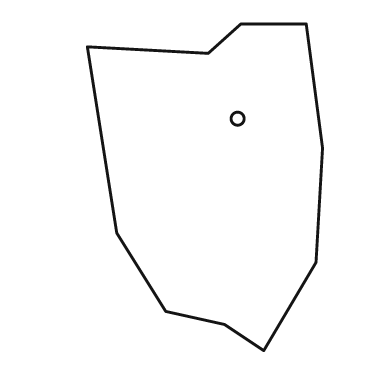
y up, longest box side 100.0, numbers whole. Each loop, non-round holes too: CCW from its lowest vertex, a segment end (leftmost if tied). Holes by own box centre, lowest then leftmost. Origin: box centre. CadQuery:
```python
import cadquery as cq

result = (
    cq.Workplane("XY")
    .moveTo(18.0, -50.0)
    .lineTo(34.0, -23.0)
    .lineTo(36.0, 12.0)
    .lineTo(31.0, 50.0)
    .lineTo(11.0, 50.0)
    .lineTo(1.0, 41.0)
    .lineTo(-36.0, 43.0)
    .lineTo(-27.0, -14.0)
    .lineTo(-12.0, -38.0)
    .lineTo(6.0, -42.0)
    .close()
    .moveTo(10.0, 21.0)
    .circle(2.0)
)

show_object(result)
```